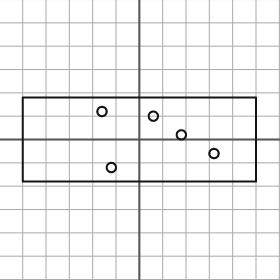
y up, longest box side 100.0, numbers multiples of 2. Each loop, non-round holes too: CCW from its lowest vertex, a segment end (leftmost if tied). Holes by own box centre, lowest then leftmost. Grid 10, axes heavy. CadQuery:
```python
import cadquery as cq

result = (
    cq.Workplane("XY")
    .moveTo(-50.0, -18.0)
    .lineTo(50.0, -18.0)
    .lineTo(50.0, 18.0)
    .lineTo(-50.0, 18.0)
    .close()
    .moveTo(-12.0, -12.0)
    .circle(2.0)
    .moveTo(32.0, -6.0)
    .circle(2.0)
    .moveTo(18.0, 2.0)
    .circle(2.0)
    .moveTo(6.0, 10.0)
    .circle(2.0)
    .moveTo(-16.0, 12.0)
    .circle(2.0)
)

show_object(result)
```